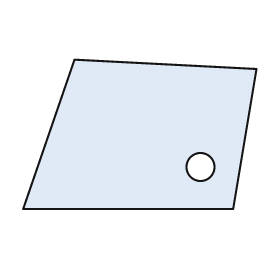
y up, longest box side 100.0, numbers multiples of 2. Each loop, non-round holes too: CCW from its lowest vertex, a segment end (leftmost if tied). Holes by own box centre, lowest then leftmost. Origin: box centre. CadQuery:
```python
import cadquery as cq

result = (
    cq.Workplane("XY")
    .moveTo(-50.0, -32.0)
    .lineTo(40.0, -32.0)
    .lineTo(50.0, 28.0)
    .lineTo(-28.0, 32.0)
    .close()
    .moveTo(26.0, -14.0)
    .circle(6.0)
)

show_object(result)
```